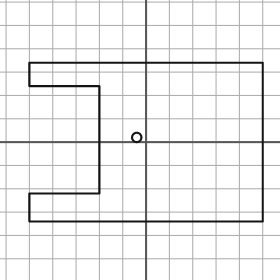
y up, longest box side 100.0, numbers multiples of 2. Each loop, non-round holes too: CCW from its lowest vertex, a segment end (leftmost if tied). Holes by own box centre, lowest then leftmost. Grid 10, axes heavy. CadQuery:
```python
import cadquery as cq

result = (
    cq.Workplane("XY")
    .moveTo(-50.0, -34.0)
    .lineTo(50.0, -34.0)
    .lineTo(50.0, 34.0)
    .lineTo(-50.0, 34.0)
    .lineTo(-50.0, 24.0)
    .lineTo(-20.0, 24.0)
    .lineTo(-20.0, -22.0)
    .lineTo(-50.0, -22.0)
    .close()
    .moveTo(-4.0, 2.0)
    .circle(2.0)
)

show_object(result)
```